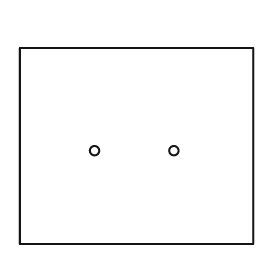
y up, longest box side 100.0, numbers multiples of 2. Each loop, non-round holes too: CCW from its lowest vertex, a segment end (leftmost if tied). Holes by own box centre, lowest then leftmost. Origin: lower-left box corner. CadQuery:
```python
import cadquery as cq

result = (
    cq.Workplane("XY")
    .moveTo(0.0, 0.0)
    .lineTo(100.0, 0.0)
    .lineTo(100.0, 84.0)
    .lineTo(0.0, 84.0)
    .close()
    .moveTo(32.0, 40.0)
    .circle(2.0)
    .moveTo(66.0, 40.0)
    .circle(2.0)
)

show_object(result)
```